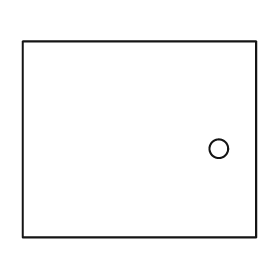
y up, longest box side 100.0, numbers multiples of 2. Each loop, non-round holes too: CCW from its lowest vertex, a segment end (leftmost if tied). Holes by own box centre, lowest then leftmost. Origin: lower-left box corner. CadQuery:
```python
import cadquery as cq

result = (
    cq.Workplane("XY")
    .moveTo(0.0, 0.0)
    .lineTo(100.0, 0.0)
    .lineTo(100.0, 84.0)
    .lineTo(0.0, 84.0)
    .close()
    .moveTo(84.0, 38.0)
    .circle(4.0)
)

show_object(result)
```